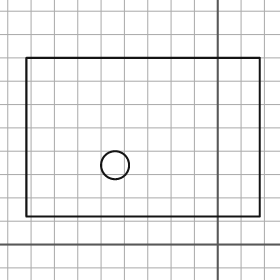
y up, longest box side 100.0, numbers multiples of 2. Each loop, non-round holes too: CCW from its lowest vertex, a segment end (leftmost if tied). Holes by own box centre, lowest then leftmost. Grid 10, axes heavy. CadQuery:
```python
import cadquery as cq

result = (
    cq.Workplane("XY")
    .moveTo(-82.0, 12.0)
    .lineTo(18.0, 12.0)
    .lineTo(18.0, 80.0)
    .lineTo(-82.0, 80.0)
    .close()
    .moveTo(-44.0, 34.0)
    .circle(6.0)
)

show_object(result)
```